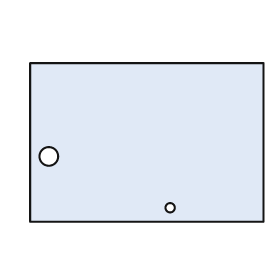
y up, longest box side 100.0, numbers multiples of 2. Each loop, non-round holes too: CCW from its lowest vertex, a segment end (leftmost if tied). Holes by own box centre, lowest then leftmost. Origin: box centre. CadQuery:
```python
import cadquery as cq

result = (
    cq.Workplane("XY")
    .moveTo(-50.0, -34.0)
    .lineTo(50.0, -34.0)
    .lineTo(50.0, 34.0)
    .lineTo(-50.0, 34.0)
    .close()
    .moveTo(10.0, -28.0)
    .circle(2.0)
    .moveTo(-42.0, -6.0)
    .circle(4.0)
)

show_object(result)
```